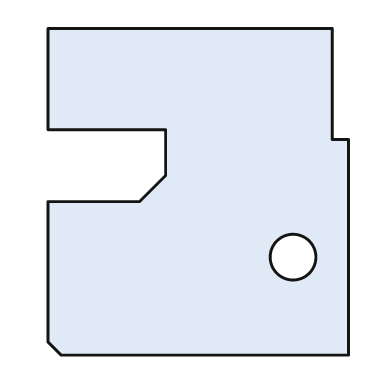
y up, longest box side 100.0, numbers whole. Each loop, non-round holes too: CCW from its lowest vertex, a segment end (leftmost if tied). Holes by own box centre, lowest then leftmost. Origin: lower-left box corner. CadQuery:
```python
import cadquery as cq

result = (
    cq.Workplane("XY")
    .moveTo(4.0, 0.0)
    .lineTo(92.0, 0.0)
    .lineTo(92.0, 66.0)
    .lineTo(87.0, 66.0)
    .lineTo(87.0, 100.0)
    .lineTo(0.0, 100.0)
    .lineTo(0.0, 69.0)
    .lineTo(36.0, 69.0)
    .lineTo(36.0, 55.0)
    .lineTo(28.0, 47.0)
    .lineTo(0.0, 47.0)
    .lineTo(0.0, 4.0)
    .close()
    .moveTo(75.0, 30.0)
    .circle(7.0)
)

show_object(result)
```